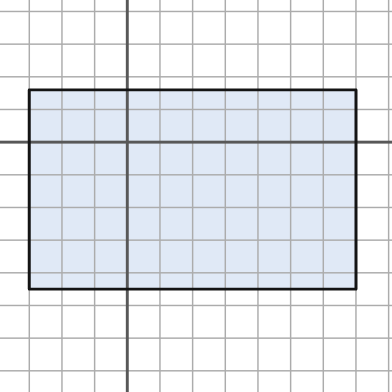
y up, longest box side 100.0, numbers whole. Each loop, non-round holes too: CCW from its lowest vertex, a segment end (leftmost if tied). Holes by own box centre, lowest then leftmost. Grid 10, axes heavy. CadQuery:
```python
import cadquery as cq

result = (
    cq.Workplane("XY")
    .moveTo(-30.0, -45.0)
    .lineTo(70.0, -45.0)
    .lineTo(70.0, 16.0)
    .lineTo(-30.0, 16.0)
    .close()
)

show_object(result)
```